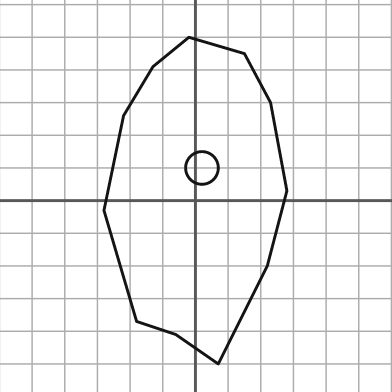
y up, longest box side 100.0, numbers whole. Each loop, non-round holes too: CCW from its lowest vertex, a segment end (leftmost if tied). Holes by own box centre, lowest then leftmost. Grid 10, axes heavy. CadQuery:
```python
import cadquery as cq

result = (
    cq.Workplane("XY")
    .moveTo(7.0, -50.0)
    .lineTo(22.0, -20.0)
    .lineTo(28.0, 3.0)
    .lineTo(23.0, 30.0)
    .lineTo(15.0, 45.0)
    .lineTo(-2.0, 50.0)
    .lineTo(-13.0, 41.0)
    .lineTo(-22.0, 26.0)
    .lineTo(-28.0, -3.0)
    .lineTo(-18.0, -37.0)
    .lineTo(-6.0, -41.0)
    .close()
    .moveTo(2.0, 10.0)
    .circle(5.0)
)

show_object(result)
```